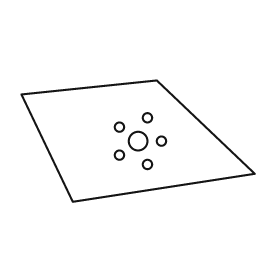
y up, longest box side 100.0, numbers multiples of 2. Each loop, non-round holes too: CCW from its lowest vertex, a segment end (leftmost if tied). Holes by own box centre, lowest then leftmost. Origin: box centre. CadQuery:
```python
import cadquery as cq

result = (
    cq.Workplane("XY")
    .moveTo(-28.0, -26.0)
    .lineTo(50.0, -14.0)
    .lineTo(8.0, 26.0)
    .lineTo(-50.0, 20.0)
    .close()
    .moveTo(4.0, -10.0)
    .circle(2.0)
    .moveTo(-8.0, -6.0)
    .circle(2.0)
    .moveTo(0.0, 0.0)
    .circle(4.0)
    .moveTo(10.0, 0.0)
    .circle(2.0)
    .moveTo(-8.0, 6.0)
    .circle(2.0)
    .moveTo(4.0, 10.0)
    .circle(2.0)
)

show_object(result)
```